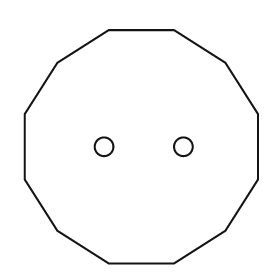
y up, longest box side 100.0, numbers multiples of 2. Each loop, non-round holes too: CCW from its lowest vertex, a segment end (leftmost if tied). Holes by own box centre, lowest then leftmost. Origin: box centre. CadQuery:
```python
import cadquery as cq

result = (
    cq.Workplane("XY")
    .moveTo(-14.0, -50.0)
    .lineTo(14.0, -50.0)
    .lineTo(36.0, -36.0)
    .lineTo(50.0, -14.0)
    .lineTo(50.0, 14.0)
    .lineTo(36.0, 36.0)
    .lineTo(14.0, 50.0)
    .lineTo(-14.0, 50.0)
    .lineTo(-36.0, 36.0)
    .lineTo(-50.0, 14.0)
    .lineTo(-50.0, -14.0)
    .lineTo(-36.0, -36.0)
    .close()
    .moveTo(-16.0, 0.0)
    .circle(4.0)
    .moveTo(18.0, 0.0)
    .circle(4.0)
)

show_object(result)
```